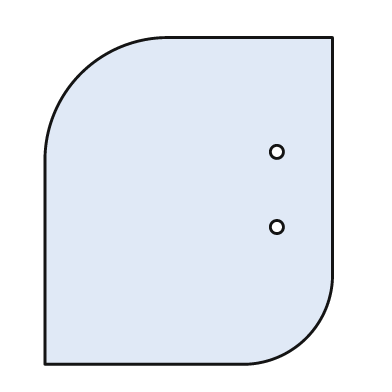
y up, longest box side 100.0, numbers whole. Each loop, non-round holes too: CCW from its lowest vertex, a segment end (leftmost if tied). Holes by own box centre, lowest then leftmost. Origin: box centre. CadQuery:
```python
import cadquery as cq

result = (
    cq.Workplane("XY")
    .moveTo(-44.0, -50.0)
    .lineTo(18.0, -50.0)
    .threePointArc((36.0, -42.0), (44.0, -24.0))
    .lineTo(44.0, 50.0)
    .lineTo(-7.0, 50.0)
    .threePointArc((-33.0, 39.0), (-44.0, 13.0))
    .close()
    .moveTo(27.0, -8.0)
    .circle(2.0)
    .moveTo(27.0, 15.0)
    .circle(2.0)
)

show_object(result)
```